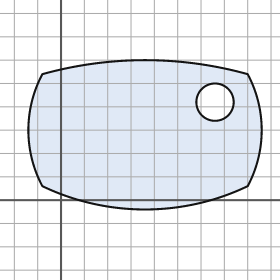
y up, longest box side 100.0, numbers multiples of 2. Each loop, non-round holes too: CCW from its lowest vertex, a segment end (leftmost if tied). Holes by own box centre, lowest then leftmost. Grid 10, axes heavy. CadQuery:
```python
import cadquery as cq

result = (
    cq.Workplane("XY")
    .moveTo(-8.0, 6.0)
    .threePointArc((36.0, -4.0), (80.0, 6.0))
    .threePointArc((86.0, 30.0), (80.0, 54.0))
    .threePointArc((36.0, 60.0), (-8.0, 54.0))
    .threePointArc((-14.0, 30.0), (-8.0, 6.0))
    .close()
    .moveTo(66.0, 42.0)
    .circle(8.0)
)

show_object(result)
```